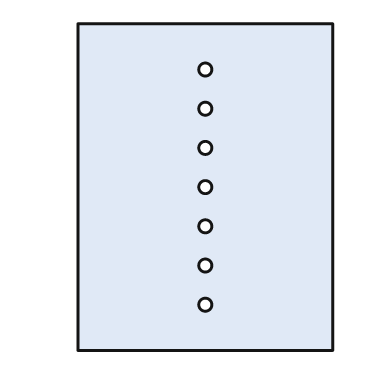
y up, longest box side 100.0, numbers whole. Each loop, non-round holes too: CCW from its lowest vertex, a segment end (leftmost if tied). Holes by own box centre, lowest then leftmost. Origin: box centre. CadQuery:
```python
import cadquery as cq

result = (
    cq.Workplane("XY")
    .moveTo(-39.0, -50.0)
    .lineTo(39.0, -50.0)
    .lineTo(39.0, 50.0)
    .lineTo(-39.0, 50.0)
    .close()
    .moveTo(0.0, -36.0)
    .circle(2.0)
    .moveTo(0.0, -24.0)
    .circle(2.0)
    .moveTo(0.0, -12.0)
    .circle(2.0)
    .moveTo(0.0, 0.0)
    .circle(2.0)
    .moveTo(0.0, 12.0)
    .circle(2.0)
    .moveTo(0.0, 24.0)
    .circle(2.0)
    .moveTo(0.0, 36.0)
    .circle(2.0)
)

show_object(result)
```